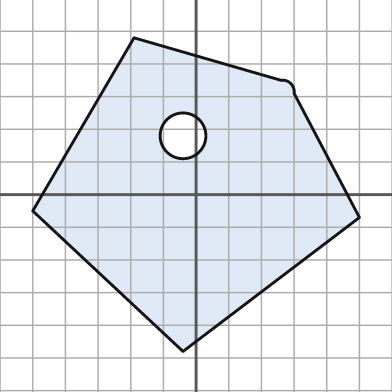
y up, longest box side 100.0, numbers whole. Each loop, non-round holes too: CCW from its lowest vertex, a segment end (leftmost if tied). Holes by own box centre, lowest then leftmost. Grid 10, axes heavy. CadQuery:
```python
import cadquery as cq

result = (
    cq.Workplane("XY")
    .moveTo(-4.0, -48.0)
    .lineTo(50.0, -7.0)
    .lineTo(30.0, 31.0)
    .threePointArc((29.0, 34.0), (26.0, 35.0))
    .lineTo(-19.0, 48.0)
    .lineTo(-50.0, -5.0)
    .close()
    .moveTo(-4.0, 18.0)
    .circle(7.0)
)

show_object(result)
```